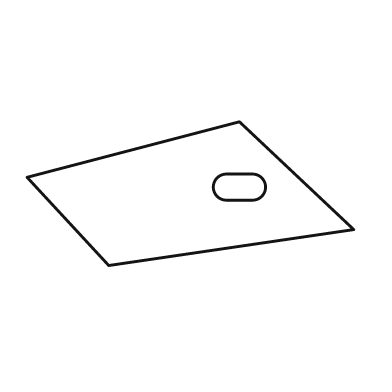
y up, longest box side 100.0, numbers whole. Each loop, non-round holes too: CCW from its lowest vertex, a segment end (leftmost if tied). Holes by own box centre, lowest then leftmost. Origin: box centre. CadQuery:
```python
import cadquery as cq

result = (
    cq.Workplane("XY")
    .moveTo(-25.0, -22.0)
    .lineTo(50.0, -11.0)
    .lineTo(15.0, 22.0)
    .lineTo(-50.0, 5.0)
    .close()
    .moveTo(11.0, -2.0)
    .lineTo(19.0, -2.0)
    .threePointArc((23.0, 2.0), (19.0, 6.0))
    .lineTo(11.0, 6.0)
    .threePointArc((7.0, 2.0), (11.0, -2.0))
    .close()
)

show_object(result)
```